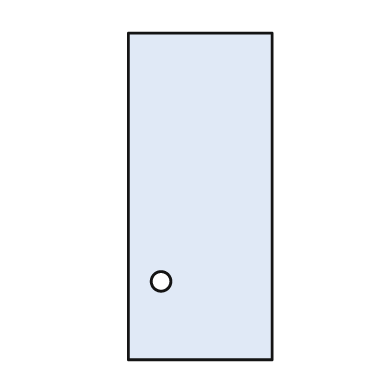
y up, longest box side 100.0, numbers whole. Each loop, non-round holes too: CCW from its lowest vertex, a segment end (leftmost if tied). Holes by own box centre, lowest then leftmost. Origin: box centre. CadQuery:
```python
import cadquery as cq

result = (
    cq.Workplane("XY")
    .moveTo(-22.0, -50.0)
    .lineTo(22.0, -50.0)
    .lineTo(22.0, 50.0)
    .lineTo(-22.0, 50.0)
    .close()
    .moveTo(-12.0, -26.0)
    .circle(3.0)
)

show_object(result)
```